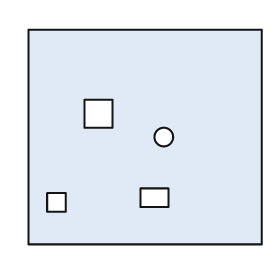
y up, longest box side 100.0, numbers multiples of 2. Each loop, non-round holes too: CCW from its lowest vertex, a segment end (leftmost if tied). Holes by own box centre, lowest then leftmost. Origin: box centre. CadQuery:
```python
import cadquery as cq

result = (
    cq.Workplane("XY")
    .moveTo(-50.0, -46.0)
    .lineTo(50.0, -46.0)
    .lineTo(50.0, 46.0)
    .lineTo(-50.0, 46.0)
    .close()
    .moveTo(-42.0, -32.0)
    .lineTo(-34.0, -32.0)
    .lineTo(-34.0, -24.0)
    .lineTo(-42.0, -24.0)
    .close()
    .moveTo(-2.0, -30.0)
    .lineTo(10.0, -30.0)
    .lineTo(10.0, -22.0)
    .lineTo(-2.0, -22.0)
    .close()
    .moveTo(8.0, 0.0)
    .circle(4.0)
    .moveTo(-26.0, 4.0)
    .lineTo(-14.0, 4.0)
    .lineTo(-14.0, 16.0)
    .lineTo(-26.0, 16.0)
    .close()
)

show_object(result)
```